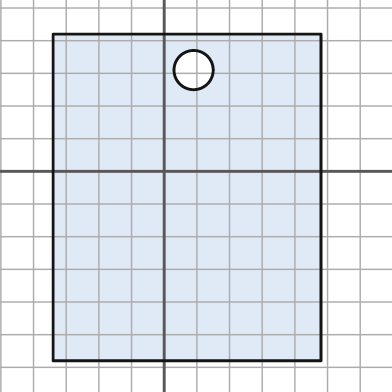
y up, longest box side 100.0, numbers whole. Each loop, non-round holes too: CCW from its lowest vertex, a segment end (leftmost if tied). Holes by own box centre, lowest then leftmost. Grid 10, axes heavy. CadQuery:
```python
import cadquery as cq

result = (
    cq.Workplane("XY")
    .moveTo(-34.0, -58.0)
    .lineTo(48.0, -58.0)
    .lineTo(48.0, 42.0)
    .lineTo(-34.0, 42.0)
    .close()
    .moveTo(9.0, 31.0)
    .circle(6.0)
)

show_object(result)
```